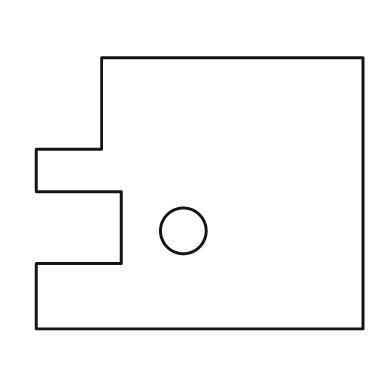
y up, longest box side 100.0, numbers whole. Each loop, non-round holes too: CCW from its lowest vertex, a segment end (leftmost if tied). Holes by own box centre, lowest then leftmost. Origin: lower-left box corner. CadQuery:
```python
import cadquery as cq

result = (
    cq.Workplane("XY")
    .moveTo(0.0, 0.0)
    .lineTo(100.0, 0.0)
    .lineTo(100.0, 83.0)
    .lineTo(20.0, 83.0)
    .lineTo(20.0, 55.0)
    .lineTo(0.0, 55.0)
    .lineTo(0.0, 42.0)
    .lineTo(26.0, 42.0)
    .lineTo(26.0, 20.0)
    .lineTo(0.0, 20.0)
    .close()
    .moveTo(45.0, 30.0)
    .circle(7.0)
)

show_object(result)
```